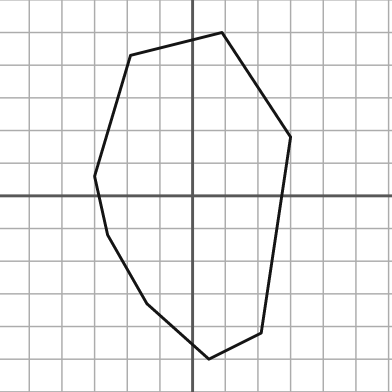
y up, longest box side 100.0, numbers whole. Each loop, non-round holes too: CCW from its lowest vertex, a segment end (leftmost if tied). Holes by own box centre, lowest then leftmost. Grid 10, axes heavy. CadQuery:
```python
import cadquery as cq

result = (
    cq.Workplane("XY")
    .moveTo(5.0, -50.0)
    .lineTo(21.0, -42.0)
    .lineTo(30.0, 18.0)
    .lineTo(9.0, 50.0)
    .lineTo(-19.0, 43.0)
    .lineTo(-30.0, 6.0)
    .lineTo(-26.0, -12.0)
    .lineTo(-14.0, -33.0)
    .close()
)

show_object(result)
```